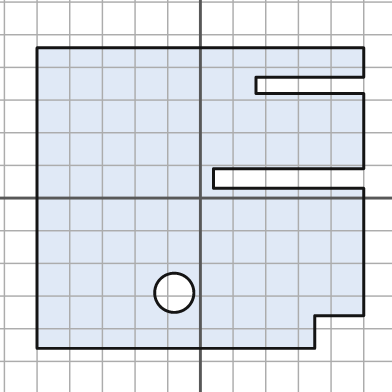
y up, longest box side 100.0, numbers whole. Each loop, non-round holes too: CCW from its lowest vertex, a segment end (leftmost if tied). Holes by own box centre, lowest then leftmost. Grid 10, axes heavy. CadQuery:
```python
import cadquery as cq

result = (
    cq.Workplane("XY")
    .moveTo(-50.0, -46.0)
    .lineTo(35.0, -46.0)
    .lineTo(35.0, -36.0)
    .lineTo(50.0, -36.0)
    .lineTo(50.0, 3.0)
    .lineTo(4.0, 3.0)
    .lineTo(4.0, 9.0)
    .lineTo(50.0, 9.0)
    .lineTo(50.0, 32.0)
    .lineTo(17.0, 32.0)
    .lineTo(17.0, 37.0)
    .lineTo(50.0, 37.0)
    .lineTo(50.0, 46.0)
    .lineTo(-50.0, 46.0)
    .close()
    .moveTo(-8.0, -29.0)
    .circle(6.0)
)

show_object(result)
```